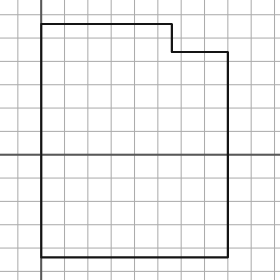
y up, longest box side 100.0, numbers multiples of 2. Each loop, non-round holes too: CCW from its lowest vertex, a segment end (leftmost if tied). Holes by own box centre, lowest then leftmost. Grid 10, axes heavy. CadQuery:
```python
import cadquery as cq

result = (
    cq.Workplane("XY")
    .moveTo(0.0, -44.0)
    .lineTo(80.0, -44.0)
    .lineTo(80.0, 44.0)
    .lineTo(56.0, 44.0)
    .lineTo(56.0, 56.0)
    .lineTo(0.0, 56.0)
    .close()
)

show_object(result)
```